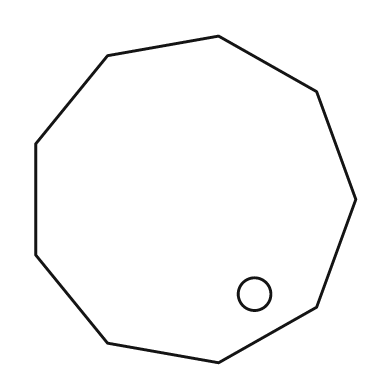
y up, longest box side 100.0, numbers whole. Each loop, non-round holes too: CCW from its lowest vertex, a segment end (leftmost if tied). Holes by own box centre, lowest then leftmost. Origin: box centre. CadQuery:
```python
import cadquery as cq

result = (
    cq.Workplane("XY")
    .moveTo(7.0, -50.0)
    .lineTo(37.0, -33.0)
    .lineTo(49.0, 0.0)
    .lineTo(37.0, 33.0)
    .lineTo(7.0, 50.0)
    .lineTo(-27.0, 44.0)
    .lineTo(-49.0, 17.0)
    .lineTo(-49.0, -17.0)
    .lineTo(-27.0, -44.0)
    .close()
    .moveTo(18.0, -29.0)
    .circle(5.0)
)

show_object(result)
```